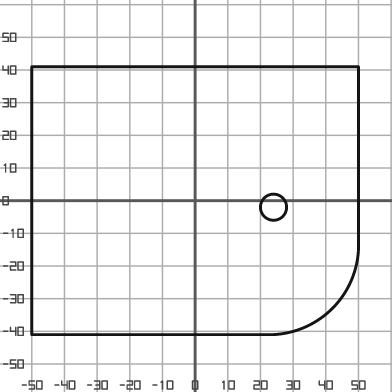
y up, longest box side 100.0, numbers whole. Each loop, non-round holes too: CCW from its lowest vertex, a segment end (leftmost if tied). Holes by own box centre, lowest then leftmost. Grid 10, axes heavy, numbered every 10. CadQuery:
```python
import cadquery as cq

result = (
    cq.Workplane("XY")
    .moveTo(-50.0, -41.0)
    .lineTo(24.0, -41.0)
    .threePointArc((42.0, -33.0), (50.0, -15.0))
    .lineTo(50.0, 41.0)
    .lineTo(-50.0, 41.0)
    .close()
    .moveTo(24.0, -2.0)
    .circle(4.0)
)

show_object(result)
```